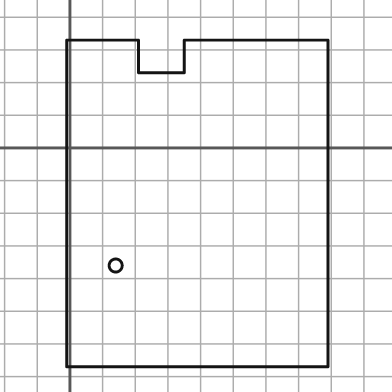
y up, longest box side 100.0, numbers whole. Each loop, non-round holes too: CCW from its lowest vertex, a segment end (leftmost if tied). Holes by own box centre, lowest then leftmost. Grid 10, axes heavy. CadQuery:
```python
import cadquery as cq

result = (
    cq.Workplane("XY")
    .moveTo(-1.0, -67.0)
    .lineTo(79.0, -67.0)
    .lineTo(79.0, 33.0)
    .lineTo(35.0, 33.0)
    .lineTo(35.0, 23.0)
    .lineTo(21.0, 23.0)
    .lineTo(21.0, 33.0)
    .lineTo(-1.0, 33.0)
    .close()
    .moveTo(14.0, -36.0)
    .circle(2.0)
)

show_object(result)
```